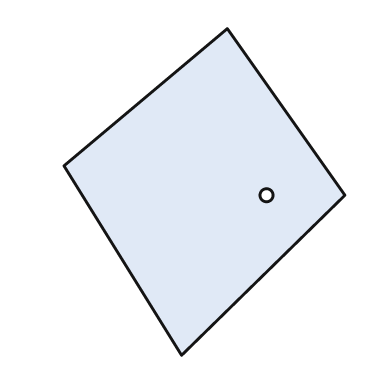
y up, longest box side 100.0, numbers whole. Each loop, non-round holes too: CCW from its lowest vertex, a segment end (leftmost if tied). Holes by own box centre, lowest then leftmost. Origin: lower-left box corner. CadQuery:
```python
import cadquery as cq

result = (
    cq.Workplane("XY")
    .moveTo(36.0, 0.0)
    .lineTo(86.0, 49.0)
    .lineTo(50.0, 100.0)
    .lineTo(0.0, 58.0)
    .close()
    .moveTo(62.0, 49.0)
    .circle(2.0)
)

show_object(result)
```